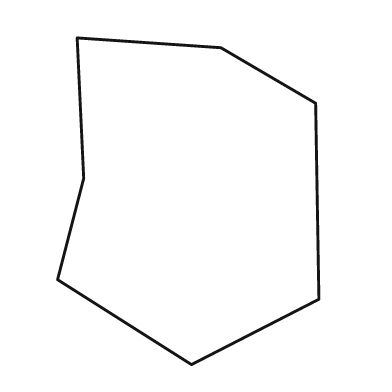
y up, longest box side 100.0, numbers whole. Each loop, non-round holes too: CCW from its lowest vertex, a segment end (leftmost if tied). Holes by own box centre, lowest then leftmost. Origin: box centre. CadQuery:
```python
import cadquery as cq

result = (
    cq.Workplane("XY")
    .moveTo(1.0, -50.0)
    .lineTo(40.0, -30.0)
    .lineTo(39.0, 30.0)
    .lineTo(10.0, 47.0)
    .lineTo(-34.0, 50.0)
    .lineTo(-32.0, 7.0)
    .lineTo(-40.0, -24.0)
    .close()
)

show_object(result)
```